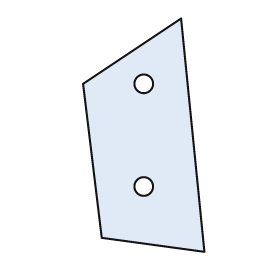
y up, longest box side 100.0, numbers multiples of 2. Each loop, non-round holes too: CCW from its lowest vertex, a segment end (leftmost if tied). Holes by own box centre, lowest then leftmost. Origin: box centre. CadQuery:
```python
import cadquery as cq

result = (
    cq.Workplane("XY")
    .moveTo(26.0, -50.0)
    .lineTo(16.0, 50.0)
    .lineTo(-26.0, 22.0)
    .lineTo(-18.0, -44.0)
    .close()
    .moveTo(0.0, -22.0)
    .circle(4.0)
    .moveTo(0.0, 22.0)
    .circle(4.0)
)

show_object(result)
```